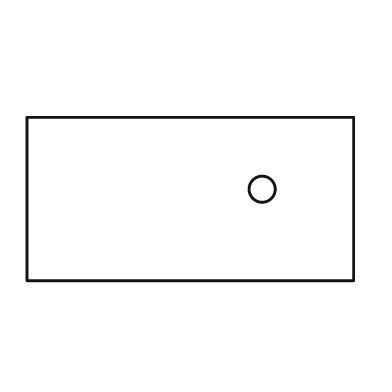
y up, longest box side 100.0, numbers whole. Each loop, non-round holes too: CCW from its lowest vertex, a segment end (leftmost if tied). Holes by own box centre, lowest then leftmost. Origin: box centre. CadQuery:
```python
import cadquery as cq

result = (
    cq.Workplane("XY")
    .moveTo(-50.0, -25.0)
    .lineTo(50.0, -25.0)
    .lineTo(50.0, 25.0)
    .lineTo(-50.0, 25.0)
    .close()
    .moveTo(22.0, 3.0)
    .circle(4.0)
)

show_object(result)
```